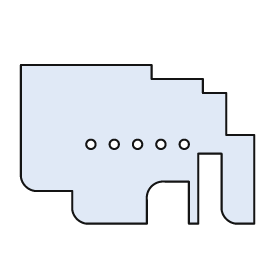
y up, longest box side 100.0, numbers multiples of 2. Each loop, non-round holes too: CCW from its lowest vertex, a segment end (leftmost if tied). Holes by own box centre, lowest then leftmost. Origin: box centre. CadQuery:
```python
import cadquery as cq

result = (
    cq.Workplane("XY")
    .moveTo(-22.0, -34.0)
    .lineTo(4.0, -34.0)
    .lineTo(4.0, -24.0)
    .threePointArc((6.0, -18.0), (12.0, -16.0))
    .lineTo(22.0, -16.0)
    .lineTo(22.0, -34.0)
    .lineTo(26.0, -34.0)
    .lineTo(26.0, -4.0)
    .lineTo(36.0, -4.0)
    .lineTo(36.0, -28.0)
    .threePointArc((38.0, -32.0), (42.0, -34.0))
    .lineTo(50.0, -34.0)
    .lineTo(50.0, 4.0)
    .lineTo(38.0, 4.0)
    .lineTo(38.0, 22.0)
    .lineTo(28.0, 22.0)
    .lineTo(28.0, 28.0)
    .lineTo(6.0, 28.0)
    .lineTo(6.0, 34.0)
    .lineTo(-50.0, 34.0)
    .lineTo(-50.0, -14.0)
    .threePointArc((-48.0, -18.0), (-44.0, -20.0))
    .lineTo(-28.0, -20.0)
    .lineTo(-28.0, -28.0)
    .threePointArc((-26.0, -32.0), (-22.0, -34.0))
    .close()
    .moveTo(-20.0, 0.0)
    .circle(2.0)
    .moveTo(-10.0, 0.0)
    .circle(2.0)
    .moveTo(0.0, 0.0)
    .circle(2.0)
    .moveTo(10.0, 0.0)
    .circle(2.0)
    .moveTo(20.0, 0.0)
    .circle(2.0)
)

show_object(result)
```